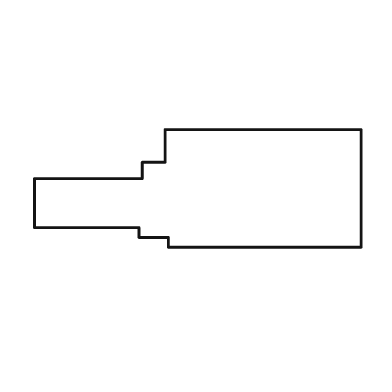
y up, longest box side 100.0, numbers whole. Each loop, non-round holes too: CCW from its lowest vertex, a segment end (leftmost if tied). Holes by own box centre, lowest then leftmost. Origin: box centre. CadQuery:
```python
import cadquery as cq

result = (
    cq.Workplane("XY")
    .moveTo(-9.0, -18.0)
    .lineTo(50.0, -18.0)
    .lineTo(50.0, 18.0)
    .lineTo(-10.0, 18.0)
    .lineTo(-10.0, 8.0)
    .lineTo(-17.0, 8.0)
    .lineTo(-17.0, 3.0)
    .lineTo(-50.0, 3.0)
    .lineTo(-50.0, -12.0)
    .lineTo(-18.0, -12.0)
    .lineTo(-18.0, -15.0)
    .lineTo(-9.0, -15.0)
    .close()
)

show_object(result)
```